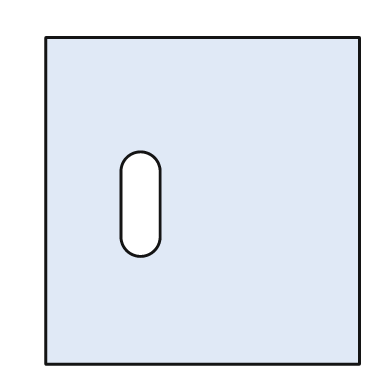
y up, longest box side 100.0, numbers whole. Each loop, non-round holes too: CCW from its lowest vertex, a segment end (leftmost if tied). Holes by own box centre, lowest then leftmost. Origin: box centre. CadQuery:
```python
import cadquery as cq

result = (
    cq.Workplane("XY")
    .moveTo(-48.0, -50.0)
    .lineTo(48.0, -50.0)
    .lineTo(48.0, 50.0)
    .lineTo(-48.0, 50.0)
    .close()
    .moveTo(-25.0, -11.0)
    .threePointArc((-19.0, -17.0), (-13.0, -11.0))
    .lineTo(-13.0, 9.0)
    .threePointArc((-19.0, 15.0), (-25.0, 9.0))
    .close()
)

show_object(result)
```